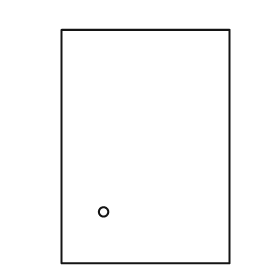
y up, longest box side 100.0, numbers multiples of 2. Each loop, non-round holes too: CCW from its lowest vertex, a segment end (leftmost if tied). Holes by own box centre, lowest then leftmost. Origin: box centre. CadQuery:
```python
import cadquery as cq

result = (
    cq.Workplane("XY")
    .moveTo(-36.0, -50.0)
    .lineTo(36.0, -50.0)
    .lineTo(36.0, 50.0)
    .lineTo(-36.0, 50.0)
    .close()
    .moveTo(-18.0, -28.0)
    .circle(2.0)
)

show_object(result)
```